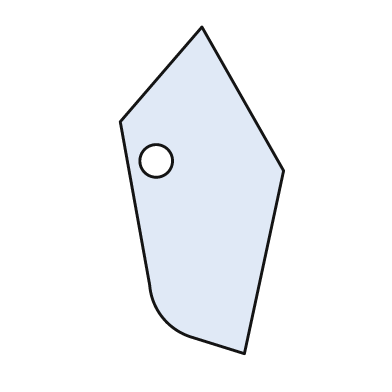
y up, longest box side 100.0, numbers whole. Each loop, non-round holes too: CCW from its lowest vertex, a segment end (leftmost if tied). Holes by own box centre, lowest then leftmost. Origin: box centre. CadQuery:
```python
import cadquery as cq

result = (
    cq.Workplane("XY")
    .moveTo(13.0, -50.0)
    .lineTo(25.0, 6.0)
    .lineTo(0.0, 50.0)
    .lineTo(-25.0, 21.0)
    .lineTo(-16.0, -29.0)
    .threePointArc((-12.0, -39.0), (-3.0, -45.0))
    .close()
    .moveTo(-14.0, 9.0)
    .circle(5.0)
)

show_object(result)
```